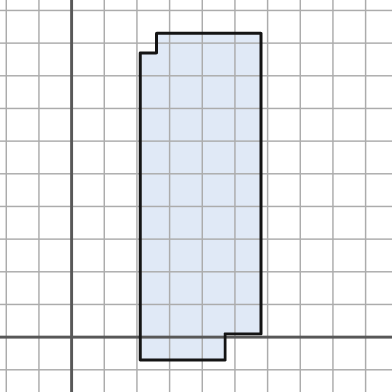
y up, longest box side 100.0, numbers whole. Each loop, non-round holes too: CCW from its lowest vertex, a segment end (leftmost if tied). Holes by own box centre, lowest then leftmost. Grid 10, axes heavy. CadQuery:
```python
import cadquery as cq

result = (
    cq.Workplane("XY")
    .moveTo(21.0, -7.0)
    .lineTo(47.0, -7.0)
    .lineTo(47.0, 1.0)
    .lineTo(58.0, 1.0)
    .lineTo(58.0, 93.0)
    .lineTo(26.0, 93.0)
    .lineTo(26.0, 87.0)
    .lineTo(21.0, 87.0)
    .close()
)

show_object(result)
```